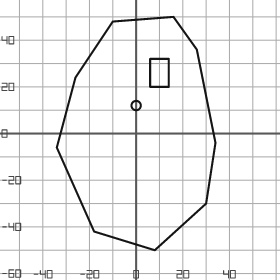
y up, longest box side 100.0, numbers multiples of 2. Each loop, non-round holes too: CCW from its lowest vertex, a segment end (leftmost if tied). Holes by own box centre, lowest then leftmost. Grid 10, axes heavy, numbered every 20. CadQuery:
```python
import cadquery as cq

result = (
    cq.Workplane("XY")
    .moveTo(8.0, -50.0)
    .lineTo(30.0, -30.0)
    .lineTo(34.0, -4.0)
    .lineTo(26.0, 36.0)
    .lineTo(16.0, 50.0)
    .lineTo(-10.0, 48.0)
    .lineTo(-26.0, 24.0)
    .lineTo(-34.0, -6.0)
    .lineTo(-18.0, -42.0)
    .close()
    .moveTo(0.0, 12.0)
    .circle(2.0)
    .moveTo(6.0, 20.0)
    .lineTo(14.0, 20.0)
    .lineTo(14.0, 32.0)
    .lineTo(6.0, 32.0)
    .close()
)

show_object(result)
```